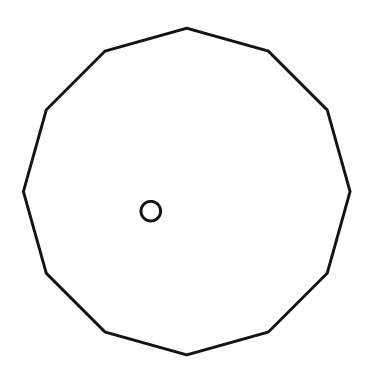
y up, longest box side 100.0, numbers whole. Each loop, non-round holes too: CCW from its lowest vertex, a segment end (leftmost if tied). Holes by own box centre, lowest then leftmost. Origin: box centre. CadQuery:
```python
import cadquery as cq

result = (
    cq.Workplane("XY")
    .moveTo(0.0, -50.0)
    .lineTo(25.0, -43.0)
    .lineTo(43.0, -25.0)
    .lineTo(50.0, 0.0)
    .lineTo(43.0, 25.0)
    .lineTo(25.0, 43.0)
    .lineTo(0.0, 50.0)
    .lineTo(-25.0, 43.0)
    .lineTo(-43.0, 25.0)
    .lineTo(-50.0, 0.0)
    .lineTo(-43.0, -25.0)
    .lineTo(-25.0, -43.0)
    .close()
    .moveTo(-11.0, -6.0)
    .circle(3.0)
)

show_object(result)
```